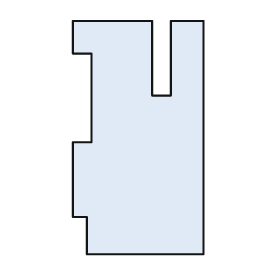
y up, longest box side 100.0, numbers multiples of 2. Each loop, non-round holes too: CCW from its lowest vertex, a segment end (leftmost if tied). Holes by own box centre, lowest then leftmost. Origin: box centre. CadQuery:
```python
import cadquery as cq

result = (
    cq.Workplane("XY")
    .moveTo(-22.0, -50.0)
    .lineTo(28.0, -50.0)
    .lineTo(28.0, 50.0)
    .lineTo(14.0, 50.0)
    .lineTo(14.0, 18.0)
    .lineTo(6.0, 18.0)
    .lineTo(6.0, 50.0)
    .lineTo(-28.0, 50.0)
    .lineTo(-28.0, 36.0)
    .lineTo(-20.0, 36.0)
    .lineTo(-20.0, -2.0)
    .lineTo(-28.0, -2.0)
    .lineTo(-28.0, -34.0)
    .lineTo(-22.0, -34.0)
    .close()
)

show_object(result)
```